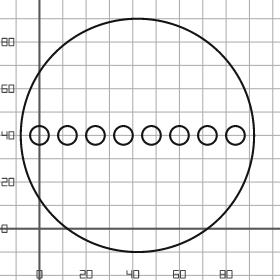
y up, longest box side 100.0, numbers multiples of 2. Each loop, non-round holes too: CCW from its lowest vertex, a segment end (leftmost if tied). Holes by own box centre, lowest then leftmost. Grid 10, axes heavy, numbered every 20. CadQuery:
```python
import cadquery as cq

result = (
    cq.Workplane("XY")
    .moveTo(42.0, 40.0)
    .circle(50.0)
    .moveTo(0.0, 40.0)
    .circle(4.0)
    .moveTo(12.0, 40.0)
    .circle(4.0)
    .moveTo(24.0, 40.0)
    .circle(4.0)
    .moveTo(36.0, 40.0)
    .circle(4.0)
    .moveTo(48.0, 40.0)
    .circle(4.0)
    .moveTo(60.0, 40.0)
    .circle(4.0)
    .moveTo(72.0, 40.0)
    .circle(4.0)
    .moveTo(84.0, 40.0)
    .circle(4.0)
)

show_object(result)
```